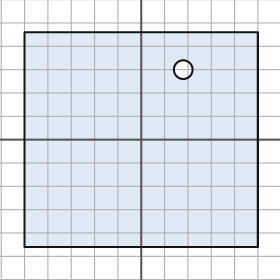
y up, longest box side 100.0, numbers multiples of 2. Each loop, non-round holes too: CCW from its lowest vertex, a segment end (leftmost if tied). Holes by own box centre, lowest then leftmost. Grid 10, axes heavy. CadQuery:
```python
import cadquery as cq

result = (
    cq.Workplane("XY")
    .moveTo(-50.0, -46.0)
    .lineTo(50.0, -46.0)
    .lineTo(50.0, 46.0)
    .lineTo(-50.0, 46.0)
    .close()
    .moveTo(18.0, 30.0)
    .circle(4.0)
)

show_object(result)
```